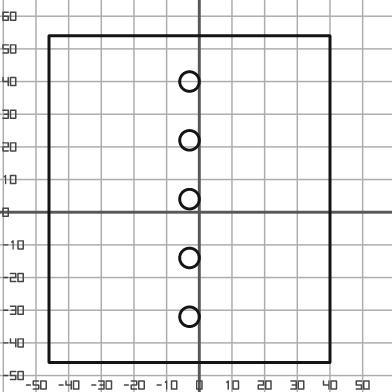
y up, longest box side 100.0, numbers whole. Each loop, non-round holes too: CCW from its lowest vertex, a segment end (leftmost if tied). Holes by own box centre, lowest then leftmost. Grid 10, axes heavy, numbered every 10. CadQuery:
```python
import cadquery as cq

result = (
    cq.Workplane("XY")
    .moveTo(-46.0, -46.0)
    .lineTo(40.0, -46.0)
    .lineTo(40.0, 54.0)
    .lineTo(-46.0, 54.0)
    .close()
    .moveTo(-3.0, -32.0)
    .circle(3.0)
    .moveTo(-3.0, -14.0)
    .circle(3.0)
    .moveTo(-3.0, 4.0)
    .circle(3.0)
    .moveTo(-3.0, 22.0)
    .circle(3.0)
    .moveTo(-3.0, 40.0)
    .circle(3.0)
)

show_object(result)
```